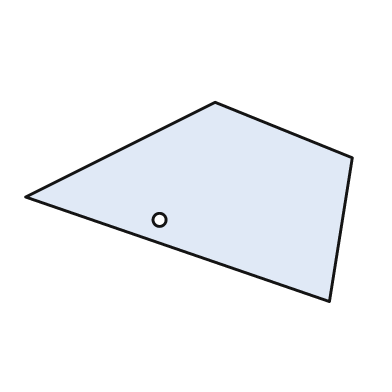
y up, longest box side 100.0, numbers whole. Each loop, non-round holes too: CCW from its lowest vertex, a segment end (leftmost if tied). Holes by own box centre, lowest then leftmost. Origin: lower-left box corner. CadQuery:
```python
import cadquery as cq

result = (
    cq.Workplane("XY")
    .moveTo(93.0, 0.0)
    .lineTo(100.0, 44.0)
    .lineTo(58.0, 61.0)
    .lineTo(0.0, 32.0)
    .close()
    .moveTo(41.0, 25.0)
    .circle(2.0)
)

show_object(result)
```